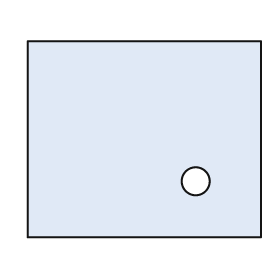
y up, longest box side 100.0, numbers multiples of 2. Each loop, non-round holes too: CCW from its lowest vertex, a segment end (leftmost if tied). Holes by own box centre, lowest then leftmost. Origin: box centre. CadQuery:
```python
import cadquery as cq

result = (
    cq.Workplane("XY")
    .moveTo(-50.0, -42.0)
    .lineTo(50.0, -42.0)
    .lineTo(50.0, 42.0)
    .lineTo(-50.0, 42.0)
    .close()
    .moveTo(22.0, -18.0)
    .circle(6.0)
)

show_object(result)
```